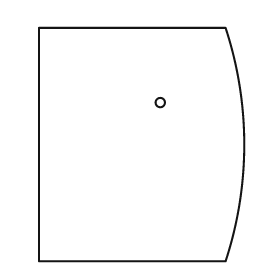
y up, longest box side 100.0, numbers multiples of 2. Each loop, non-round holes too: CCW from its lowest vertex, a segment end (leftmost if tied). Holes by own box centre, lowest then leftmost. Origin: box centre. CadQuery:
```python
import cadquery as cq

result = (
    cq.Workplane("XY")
    .moveTo(-44.0, -50.0)
    .lineTo(36.0, -50.0)
    .threePointArc((44.0, 0.0), (36.0, 50.0))
    .lineTo(-44.0, 50.0)
    .close()
    .moveTo(8.0, 18.0)
    .circle(2.0)
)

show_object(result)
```